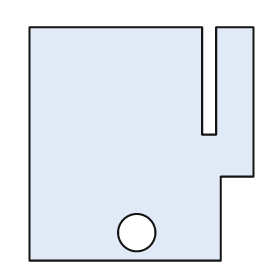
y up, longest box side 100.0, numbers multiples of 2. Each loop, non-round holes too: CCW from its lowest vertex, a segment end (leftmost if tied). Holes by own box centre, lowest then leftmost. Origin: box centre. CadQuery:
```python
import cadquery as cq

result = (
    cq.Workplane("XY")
    .moveTo(-48.0, -50.0)
    .lineTo(34.0, -50.0)
    .lineTo(34.0, -14.0)
    .lineTo(48.0, -14.0)
    .lineTo(48.0, 50.0)
    .lineTo(32.0, 50.0)
    .lineTo(32.0, 4.0)
    .lineTo(26.0, 4.0)
    .lineTo(26.0, 50.0)
    .lineTo(-48.0, 50.0)
    .close()
    .moveTo(-2.0, -38.0)
    .circle(8.0)
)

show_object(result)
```